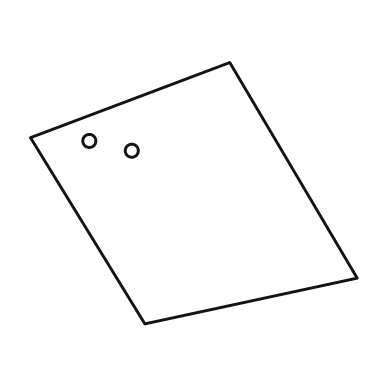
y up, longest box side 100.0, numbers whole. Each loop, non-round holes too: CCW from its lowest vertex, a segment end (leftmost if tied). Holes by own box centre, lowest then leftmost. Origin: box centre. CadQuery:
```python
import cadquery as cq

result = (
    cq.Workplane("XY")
    .moveTo(-15.0, -40.0)
    .lineTo(50.0, -26.0)
    .lineTo(11.0, 40.0)
    .lineTo(-50.0, 17.0)
    .close()
    .moveTo(-19.0, 13.0)
    .circle(2.0)
    .moveTo(-32.0, 16.0)
    .circle(2.0)
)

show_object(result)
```